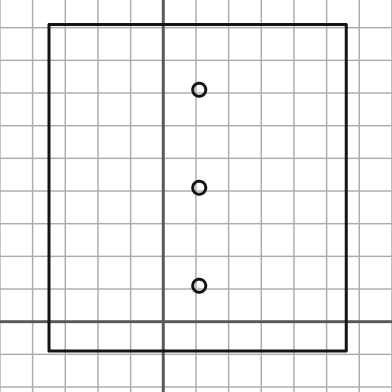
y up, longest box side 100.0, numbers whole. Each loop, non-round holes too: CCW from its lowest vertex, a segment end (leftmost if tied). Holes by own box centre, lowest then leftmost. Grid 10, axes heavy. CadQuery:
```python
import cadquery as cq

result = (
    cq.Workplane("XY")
    .moveTo(-35.0, -9.0)
    .lineTo(56.0, -9.0)
    .lineTo(56.0, 91.0)
    .lineTo(-35.0, 91.0)
    .close()
    .moveTo(11.0, 11.0)
    .circle(2.0)
    .moveTo(11.0, 41.0)
    .circle(2.0)
    .moveTo(11.0, 71.0)
    .circle(2.0)
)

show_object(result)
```